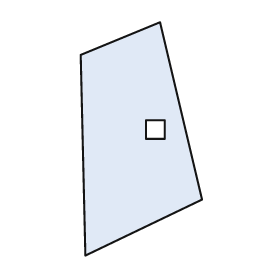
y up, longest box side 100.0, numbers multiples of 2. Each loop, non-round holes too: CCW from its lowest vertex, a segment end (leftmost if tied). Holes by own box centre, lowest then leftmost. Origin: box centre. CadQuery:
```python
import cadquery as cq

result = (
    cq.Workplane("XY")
    .moveTo(-24.0, -50.0)
    .lineTo(26.0, -26.0)
    .lineTo(8.0, 50.0)
    .lineTo(-26.0, 36.0)
    .close()
    .moveTo(2.0, 0.0)
    .lineTo(10.0, 0.0)
    .lineTo(10.0, 8.0)
    .lineTo(2.0, 8.0)
    .close()
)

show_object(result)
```